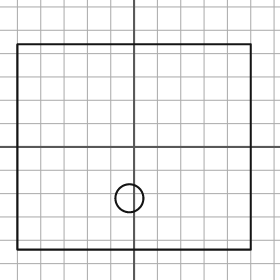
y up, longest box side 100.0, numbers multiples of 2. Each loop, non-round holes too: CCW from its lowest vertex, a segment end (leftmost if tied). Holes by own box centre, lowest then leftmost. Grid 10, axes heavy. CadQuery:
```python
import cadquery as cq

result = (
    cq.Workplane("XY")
    .moveTo(-50.0, -44.0)
    .lineTo(50.0, -44.0)
    .lineTo(50.0, 44.0)
    .lineTo(-50.0, 44.0)
    .close()
    .moveTo(-2.0, -22.0)
    .circle(6.0)
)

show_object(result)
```